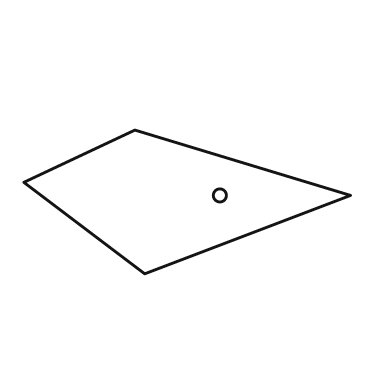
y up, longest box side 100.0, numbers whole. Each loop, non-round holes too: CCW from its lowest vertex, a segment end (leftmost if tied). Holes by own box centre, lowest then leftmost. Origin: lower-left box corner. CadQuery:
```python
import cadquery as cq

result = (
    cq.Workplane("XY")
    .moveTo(37.0, 0.0)
    .lineTo(100.0, 24.0)
    .lineTo(34.0, 44.0)
    .lineTo(0.0, 28.0)
    .close()
    .moveTo(60.0, 24.0)
    .circle(2.0)
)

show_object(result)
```